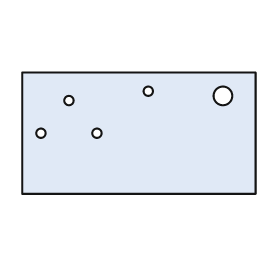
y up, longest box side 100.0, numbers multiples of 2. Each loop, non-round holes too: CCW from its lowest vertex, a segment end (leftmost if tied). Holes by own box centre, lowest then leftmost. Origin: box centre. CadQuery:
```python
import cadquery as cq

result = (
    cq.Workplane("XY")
    .moveTo(-50.0, -26.0)
    .lineTo(50.0, -26.0)
    .lineTo(50.0, 26.0)
    .lineTo(-50.0, 26.0)
    .close()
    .moveTo(-42.0, 0.0)
    .circle(2.0)
    .moveTo(-18.0, 0.0)
    .circle(2.0)
    .moveTo(-30.0, 14.0)
    .circle(2.0)
    .moveTo(36.0, 16.0)
    .circle(4.0)
    .moveTo(4.0, 18.0)
    .circle(2.0)
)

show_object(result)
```